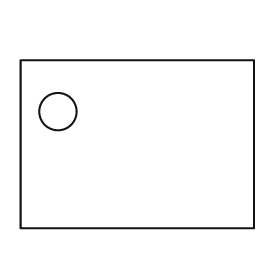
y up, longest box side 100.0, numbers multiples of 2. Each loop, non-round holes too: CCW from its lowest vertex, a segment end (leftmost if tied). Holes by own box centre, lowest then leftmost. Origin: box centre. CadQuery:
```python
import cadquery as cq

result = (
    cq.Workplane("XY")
    .moveTo(-50.0, -36.0)
    .lineTo(50.0, -36.0)
    .lineTo(50.0, 36.0)
    .lineTo(-50.0, 36.0)
    .close()
    .moveTo(-34.0, 14.0)
    .circle(8.0)
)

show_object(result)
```